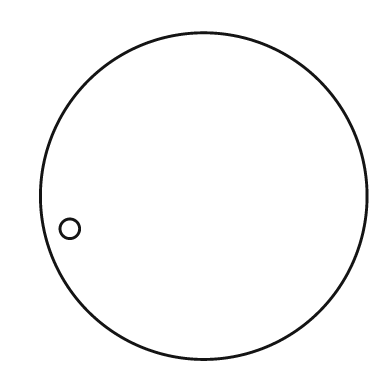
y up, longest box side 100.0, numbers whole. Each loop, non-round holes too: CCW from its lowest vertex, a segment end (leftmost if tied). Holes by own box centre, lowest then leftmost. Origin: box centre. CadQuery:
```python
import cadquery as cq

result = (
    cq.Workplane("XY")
    .moveTo(0.0, 0.0)
    .circle(50.0)
    .moveTo(-41.0, -10.0)
    .circle(3.0)
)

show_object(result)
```